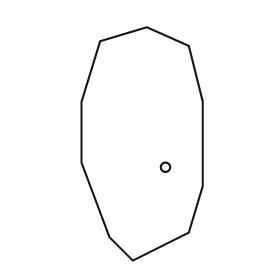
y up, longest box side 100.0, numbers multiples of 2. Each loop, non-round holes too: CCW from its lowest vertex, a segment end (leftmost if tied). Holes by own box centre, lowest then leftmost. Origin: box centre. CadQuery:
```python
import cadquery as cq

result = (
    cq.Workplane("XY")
    .moveTo(-4.0, -50.0)
    .lineTo(20.0, -38.0)
    .lineTo(26.0, -18.0)
    .lineTo(26.0, 18.0)
    .lineTo(20.0, 42.0)
    .lineTo(2.0, 50.0)
    .lineTo(-18.0, 44.0)
    .lineTo(-26.0, 18.0)
    .lineTo(-26.0, -8.0)
    .lineTo(-14.0, -40.0)
    .close()
    .moveTo(10.0, -10.0)
    .circle(2.0)
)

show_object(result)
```